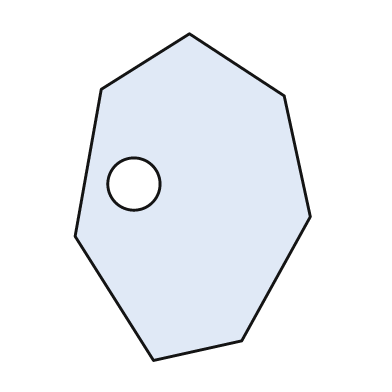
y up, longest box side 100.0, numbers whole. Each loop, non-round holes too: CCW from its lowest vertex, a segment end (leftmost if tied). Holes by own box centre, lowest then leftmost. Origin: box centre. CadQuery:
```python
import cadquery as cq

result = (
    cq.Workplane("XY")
    .moveTo(-12.0, -50.0)
    .lineTo(15.0, -44.0)
    .lineTo(36.0, -6.0)
    .lineTo(28.0, 31.0)
    .lineTo(-1.0, 50.0)
    .lineTo(-28.0, 33.0)
    .lineTo(-36.0, -12.0)
    .close()
    .moveTo(-18.0, 4.0)
    .circle(8.0)
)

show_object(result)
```